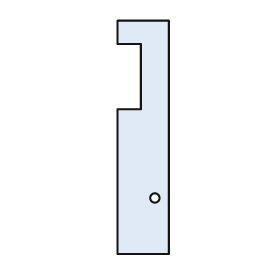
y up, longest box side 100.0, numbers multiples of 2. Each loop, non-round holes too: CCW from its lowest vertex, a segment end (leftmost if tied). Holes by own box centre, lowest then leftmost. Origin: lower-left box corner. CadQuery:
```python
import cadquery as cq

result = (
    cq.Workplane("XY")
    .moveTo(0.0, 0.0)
    .lineTo(22.0, 0.0)
    .lineTo(22.0, 100.0)
    .lineTo(0.0, 100.0)
    .lineTo(0.0, 90.0)
    .lineTo(10.0, 90.0)
    .lineTo(10.0, 62.0)
    .lineTo(0.0, 62.0)
    .close()
    .moveTo(16.0, 24.0)
    .circle(2.0)
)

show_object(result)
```